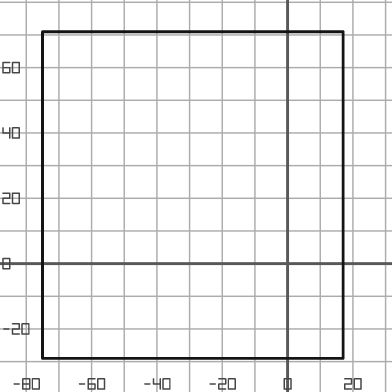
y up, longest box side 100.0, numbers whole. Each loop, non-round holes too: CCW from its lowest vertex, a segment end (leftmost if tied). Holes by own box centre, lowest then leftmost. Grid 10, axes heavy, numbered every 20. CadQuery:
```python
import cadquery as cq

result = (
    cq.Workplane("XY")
    .moveTo(-75.0, -29.0)
    .lineTo(17.0, -29.0)
    .lineTo(17.0, 71.0)
    .lineTo(-75.0, 71.0)
    .close()
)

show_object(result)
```